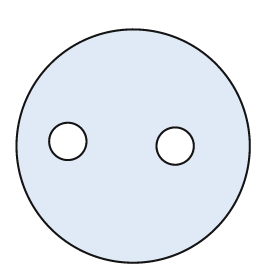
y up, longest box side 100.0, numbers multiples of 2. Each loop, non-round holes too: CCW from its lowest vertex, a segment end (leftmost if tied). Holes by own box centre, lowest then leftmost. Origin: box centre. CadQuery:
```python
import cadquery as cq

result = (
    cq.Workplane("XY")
    .moveTo(0.0, 0.0)
    .circle(50.0)
    .moveTo(18.0, 0.0)
    .circle(8.0)
    .moveTo(-28.0, 2.0)
    .circle(8.0)
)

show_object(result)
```